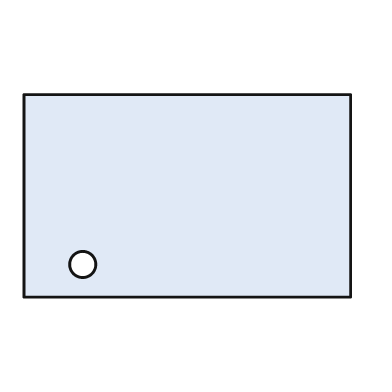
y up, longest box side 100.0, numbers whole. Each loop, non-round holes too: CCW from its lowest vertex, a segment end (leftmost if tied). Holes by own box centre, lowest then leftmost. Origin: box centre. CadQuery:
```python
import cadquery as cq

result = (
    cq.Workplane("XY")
    .moveTo(-50.0, -31.0)
    .lineTo(50.0, -31.0)
    .lineTo(50.0, 31.0)
    .lineTo(-50.0, 31.0)
    .close()
    .moveTo(-32.0, -21.0)
    .circle(4.0)
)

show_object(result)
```